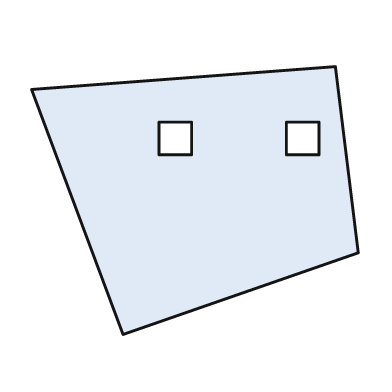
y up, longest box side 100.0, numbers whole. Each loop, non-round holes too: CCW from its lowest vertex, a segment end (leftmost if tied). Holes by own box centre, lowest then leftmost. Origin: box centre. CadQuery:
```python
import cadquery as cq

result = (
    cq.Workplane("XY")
    .moveTo(-22.0, -41.0)
    .lineTo(50.0, -16.0)
    .lineTo(43.0, 41.0)
    .lineTo(-50.0, 34.0)
    .close()
    .moveTo(-11.0, 14.0)
    .lineTo(-1.0, 14.0)
    .lineTo(-1.0, 24.0)
    .lineTo(-11.0, 24.0)
    .close()
    .moveTo(28.0, 14.0)
    .lineTo(38.0, 14.0)
    .lineTo(38.0, 24.0)
    .lineTo(28.0, 24.0)
    .close()
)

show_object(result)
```